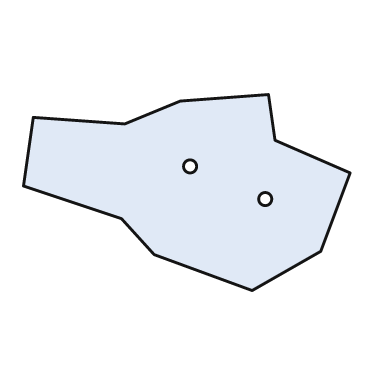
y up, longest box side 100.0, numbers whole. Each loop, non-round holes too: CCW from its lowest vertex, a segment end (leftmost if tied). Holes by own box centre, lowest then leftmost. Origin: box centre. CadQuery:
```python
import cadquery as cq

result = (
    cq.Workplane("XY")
    .moveTo(20.0, -30.0)
    .lineTo(41.0, -18.0)
    .lineTo(50.0, 6.0)
    .lineTo(27.0, 16.0)
    .lineTo(25.0, 30.0)
    .lineTo(-2.0, 28.0)
    .lineTo(-19.0, 21.0)
    .lineTo(-47.0, 23.0)
    .lineTo(-50.0, 2.0)
    .lineTo(-20.0, -8.0)
    .lineTo(-10.0, -19.0)
    .close()
    .moveTo(24.0, -2.0)
    .circle(2.0)
    .moveTo(1.0, 8.0)
    .circle(2.0)
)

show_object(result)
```